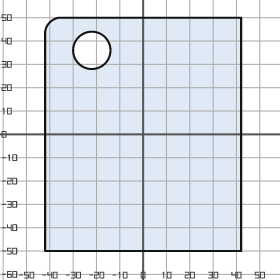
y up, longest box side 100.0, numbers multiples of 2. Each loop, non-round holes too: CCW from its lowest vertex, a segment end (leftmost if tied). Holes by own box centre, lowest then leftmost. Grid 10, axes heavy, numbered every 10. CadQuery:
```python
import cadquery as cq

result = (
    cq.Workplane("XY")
    .moveTo(-42.0, -50.0)
    .lineTo(42.0, -50.0)
    .lineTo(42.0, 50.0)
    .lineTo(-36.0, 50.0)
    .threePointArc((-40.0, 48.0), (-42.0, 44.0))
    .close()
    .moveTo(-22.0, 36.0)
    .circle(8.0)
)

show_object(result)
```